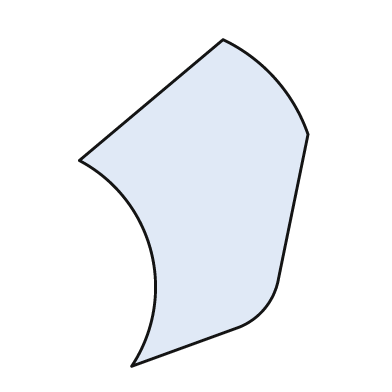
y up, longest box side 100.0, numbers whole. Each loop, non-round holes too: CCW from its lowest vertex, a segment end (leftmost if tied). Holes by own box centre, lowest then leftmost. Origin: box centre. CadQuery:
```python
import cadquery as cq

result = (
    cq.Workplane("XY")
    .moveTo(-19.0, -50.0)
    .lineTo(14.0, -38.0)
    .threePointArc((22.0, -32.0), (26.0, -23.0))
    .lineTo(35.0, 21.0)
    .threePointArc((25.0, 38.0), (9.0, 50.0))
    .lineTo(-35.0, 13.0)
    .threePointArc((-13.0, -15.0), (-19.0, -50.0))
    .close()
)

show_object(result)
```